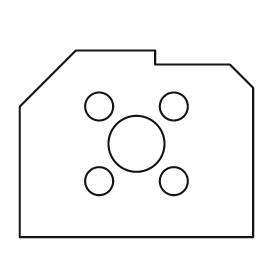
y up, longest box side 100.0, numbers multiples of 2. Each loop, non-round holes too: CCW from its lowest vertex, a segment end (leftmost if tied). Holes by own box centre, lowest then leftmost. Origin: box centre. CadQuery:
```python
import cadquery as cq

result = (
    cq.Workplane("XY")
    .moveTo(-50.0, -40.0)
    .lineTo(50.0, -40.0)
    .lineTo(50.0, 24.0)
    .lineTo(40.0, 34.0)
    .lineTo(8.0, 34.0)
    .lineTo(8.0, 40.0)
    .lineTo(-26.0, 40.0)
    .lineTo(-50.0, 16.0)
    .close()
    .moveTo(-16.0, -16.0)
    .circle(6.0)
    .moveTo(16.0, -16.0)
    .circle(6.0)
    .moveTo(0.0, 0.0)
    .circle(12.0)
    .moveTo(-16.0, 16.0)
    .circle(6.0)
    .moveTo(16.0, 16.0)
    .circle(6.0)
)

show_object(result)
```